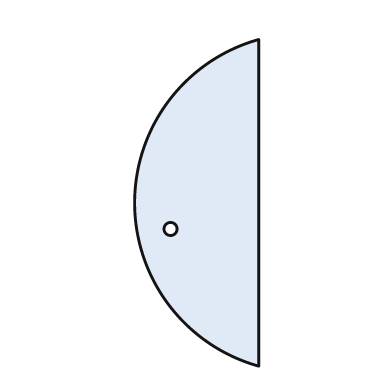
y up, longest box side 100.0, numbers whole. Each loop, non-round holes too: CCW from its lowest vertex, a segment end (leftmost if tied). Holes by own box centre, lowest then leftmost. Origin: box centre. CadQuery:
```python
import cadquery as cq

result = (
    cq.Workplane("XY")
    .moveTo(19.0, -50.0)
    .lineTo(19.0, 50.0)
    .threePointArc((-19.0, 0.0), (19.0, -50.0))
    .close()
    .moveTo(-8.0, -8.0)
    .circle(2.0)
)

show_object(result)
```